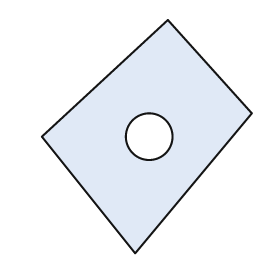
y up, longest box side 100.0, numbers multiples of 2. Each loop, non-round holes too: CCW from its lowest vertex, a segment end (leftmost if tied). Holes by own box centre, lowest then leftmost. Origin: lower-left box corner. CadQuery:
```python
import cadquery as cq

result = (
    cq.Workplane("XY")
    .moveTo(40.0, 0.0)
    .lineTo(90.0, 60.0)
    .lineTo(54.0, 100.0)
    .lineTo(0.0, 50.0)
    .close()
    .moveTo(46.0, 50.0)
    .circle(10.0)
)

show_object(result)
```